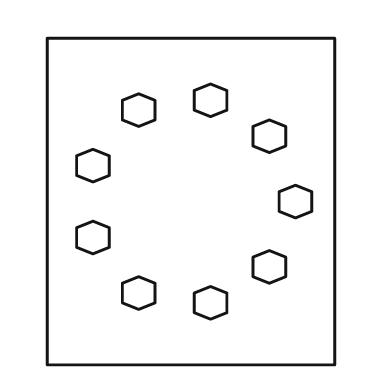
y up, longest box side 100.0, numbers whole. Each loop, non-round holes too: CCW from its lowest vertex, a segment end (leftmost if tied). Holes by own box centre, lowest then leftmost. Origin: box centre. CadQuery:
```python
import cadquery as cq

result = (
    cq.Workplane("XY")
    .moveTo(-44.0, -50.0)
    .lineTo(44.0, -50.0)
    .lineTo(44.0, 50.0)
    .lineTo(-44.0, 50.0)
    .close()
    .moveTo(6.0, -36.0)
    .lineTo(11.0, -34.0)
    .lineTo(11.0, -28.0)
    .lineTo(6.0, -26.0)
    .lineTo(1.0, -28.0)
    .lineTo(1.0, -34.0)
    .close()
    .moveTo(-16.0, -33.0)
    .lineTo(-11.0, -31.0)
    .lineTo(-11.0, -25.0)
    .lineTo(-16.0, -23.0)
    .lineTo(-21.0, -25.0)
    .lineTo(-21.0, -31.0)
    .close()
    .moveTo(24.0, -25.0)
    .lineTo(29.0, -23.0)
    .lineTo(29.0, -17.0)
    .lineTo(24.0, -15.0)
    .lineTo(19.0, -17.0)
    .lineTo(19.0, -23.0)
    .close()
    .moveTo(-30.0, -16.0)
    .lineTo(-25.0, -14.0)
    .lineTo(-25.0, -8.0)
    .lineTo(-30.0, -6.0)
    .lineTo(-35.0, -8.0)
    .lineTo(-35.0, -14.0)
    .close()
    .moveTo(32.0, -5.0)
    .lineTo(37.0, -3.0)
    .lineTo(37.0, 3.0)
    .lineTo(32.0, 5.0)
    .lineTo(27.0, 3.0)
    .lineTo(27.0, -3.0)
    .close()
    .moveTo(-30.0, 6.0)
    .lineTo(-25.0, 8.0)
    .lineTo(-25.0, 14.0)
    .lineTo(-30.0, 16.0)
    .lineTo(-35.0, 14.0)
    .lineTo(-35.0, 8.0)
    .close()
    .moveTo(24.0, 15.0)
    .lineTo(29.0, 17.0)
    .lineTo(29.0, 23.0)
    .lineTo(24.0, 25.0)
    .lineTo(19.0, 23.0)
    .lineTo(19.0, 17.0)
    .close()
    .moveTo(-16.0, 23.0)
    .lineTo(-11.0, 25.0)
    .lineTo(-11.0, 31.0)
    .lineTo(-16.0, 33.0)
    .lineTo(-21.0, 31.0)
    .lineTo(-21.0, 25.0)
    .close()
    .moveTo(6.0, 26.0)
    .lineTo(11.0, 28.0)
    .lineTo(11.0, 34.0)
    .lineTo(6.0, 36.0)
    .lineTo(1.0, 34.0)
    .lineTo(1.0, 28.0)
    .close()
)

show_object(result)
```